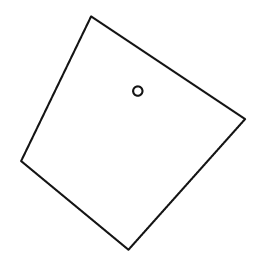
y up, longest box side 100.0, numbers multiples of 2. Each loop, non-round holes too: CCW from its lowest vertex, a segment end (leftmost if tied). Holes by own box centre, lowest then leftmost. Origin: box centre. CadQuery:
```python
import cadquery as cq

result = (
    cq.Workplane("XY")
    .moveTo(-2.0, -50.0)
    .lineTo(48.0, 6.0)
    .lineTo(-18.0, 50.0)
    .lineTo(-48.0, -12.0)
    .close()
    .moveTo(2.0, 18.0)
    .circle(2.0)
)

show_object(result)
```